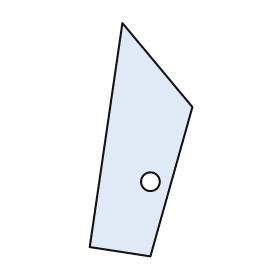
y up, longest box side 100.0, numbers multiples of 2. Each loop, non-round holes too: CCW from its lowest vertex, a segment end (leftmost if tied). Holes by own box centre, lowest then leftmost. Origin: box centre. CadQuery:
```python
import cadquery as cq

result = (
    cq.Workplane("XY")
    .moveTo(4.0, -50.0)
    .lineTo(22.0, 14.0)
    .lineTo(-8.0, 50.0)
    .lineTo(-22.0, -46.0)
    .close()
    .moveTo(4.0, -18.0)
    .circle(4.0)
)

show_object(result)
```